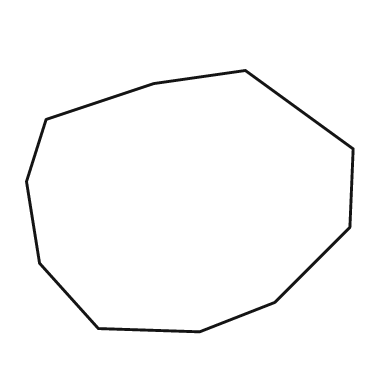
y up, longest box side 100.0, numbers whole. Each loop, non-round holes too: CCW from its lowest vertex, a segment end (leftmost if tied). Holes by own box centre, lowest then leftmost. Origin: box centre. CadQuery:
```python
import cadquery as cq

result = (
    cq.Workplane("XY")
    .moveTo(3.0, -40.0)
    .lineTo(26.0, -31.0)
    .lineTo(49.0, -8.0)
    .lineTo(50.0, 16.0)
    .lineTo(17.0, 40.0)
    .lineTo(-11.0, 36.0)
    .lineTo(-44.0, 25.0)
    .lineTo(-50.0, 6.0)
    .lineTo(-46.0, -19.0)
    .lineTo(-28.0, -39.0)
    .close()
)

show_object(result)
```